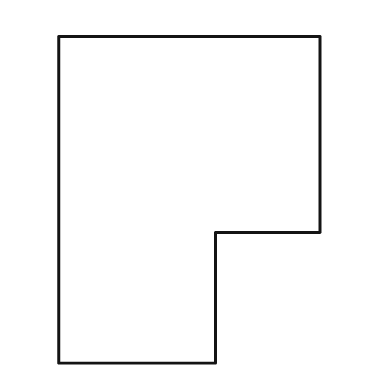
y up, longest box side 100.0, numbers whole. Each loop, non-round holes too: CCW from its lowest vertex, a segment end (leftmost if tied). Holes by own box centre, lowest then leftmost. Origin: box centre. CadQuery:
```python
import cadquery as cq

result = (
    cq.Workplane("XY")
    .moveTo(-40.0, -50.0)
    .lineTo(8.0, -50.0)
    .lineTo(8.0, -10.0)
    .lineTo(40.0, -10.0)
    .lineTo(40.0, 50.0)
    .lineTo(-40.0, 50.0)
    .close()
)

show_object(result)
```